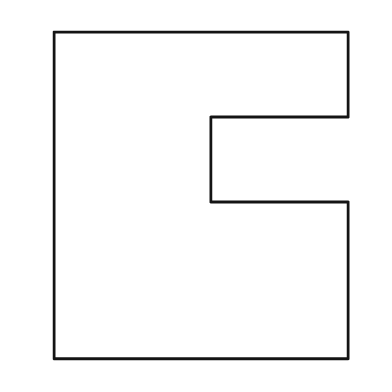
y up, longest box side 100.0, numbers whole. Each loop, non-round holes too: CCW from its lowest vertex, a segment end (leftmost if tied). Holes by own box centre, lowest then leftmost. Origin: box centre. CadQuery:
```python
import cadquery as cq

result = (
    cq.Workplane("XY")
    .moveTo(-45.0, -50.0)
    .lineTo(45.0, -50.0)
    .lineTo(45.0, -2.0)
    .lineTo(3.0, -2.0)
    .lineTo(3.0, 24.0)
    .lineTo(45.0, 24.0)
    .lineTo(45.0, 50.0)
    .lineTo(-45.0, 50.0)
    .close()
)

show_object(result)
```